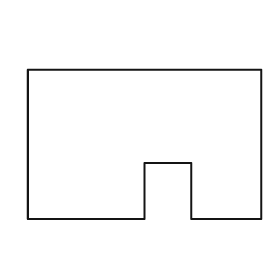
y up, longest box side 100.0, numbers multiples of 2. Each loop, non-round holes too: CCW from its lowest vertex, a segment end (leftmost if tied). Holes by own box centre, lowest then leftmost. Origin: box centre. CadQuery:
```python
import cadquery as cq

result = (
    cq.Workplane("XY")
    .moveTo(-50.0, -32.0)
    .lineTo(0.0, -32.0)
    .lineTo(0.0, -8.0)
    .lineTo(20.0, -8.0)
    .lineTo(20.0, -32.0)
    .lineTo(50.0, -32.0)
    .lineTo(50.0, 32.0)
    .lineTo(-50.0, 32.0)
    .close()
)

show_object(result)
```